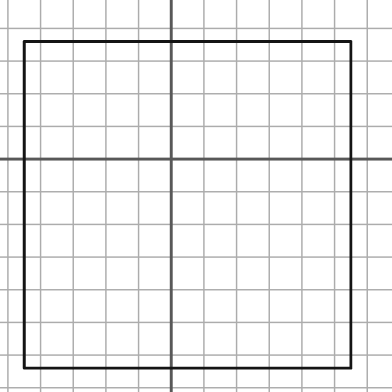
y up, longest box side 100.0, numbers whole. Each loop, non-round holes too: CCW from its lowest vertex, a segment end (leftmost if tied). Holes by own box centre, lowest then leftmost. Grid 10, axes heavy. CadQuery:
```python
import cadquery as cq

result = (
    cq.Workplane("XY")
    .moveTo(-45.0, -64.0)
    .lineTo(55.0, -64.0)
    .lineTo(55.0, 36.0)
    .lineTo(-45.0, 36.0)
    .close()
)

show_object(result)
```